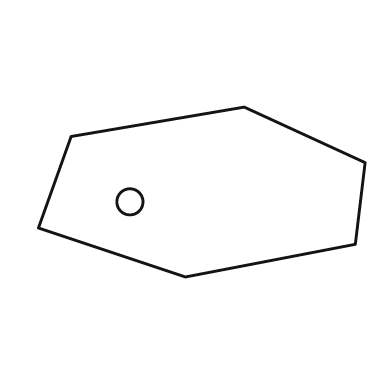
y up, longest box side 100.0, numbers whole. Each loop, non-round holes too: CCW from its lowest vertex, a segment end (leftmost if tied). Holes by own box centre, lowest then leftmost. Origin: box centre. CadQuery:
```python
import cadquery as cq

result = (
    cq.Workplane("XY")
    .moveTo(-5.0, -26.0)
    .lineTo(47.0, -16.0)
    .lineTo(50.0, 9.0)
    .lineTo(13.0, 26.0)
    .lineTo(-40.0, 17.0)
    .lineTo(-50.0, -11.0)
    .close()
    .moveTo(-22.0, -3.0)
    .circle(4.0)
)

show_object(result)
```